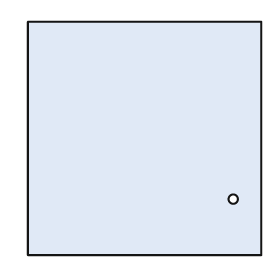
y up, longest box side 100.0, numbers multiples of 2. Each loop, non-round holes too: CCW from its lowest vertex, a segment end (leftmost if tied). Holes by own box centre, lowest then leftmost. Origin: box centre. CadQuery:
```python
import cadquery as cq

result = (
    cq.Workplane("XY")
    .moveTo(-50.0, -50.0)
    .lineTo(50.0, -50.0)
    .lineTo(50.0, 50.0)
    .lineTo(-50.0, 50.0)
    .close()
    .moveTo(38.0, -26.0)
    .circle(2.0)
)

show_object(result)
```